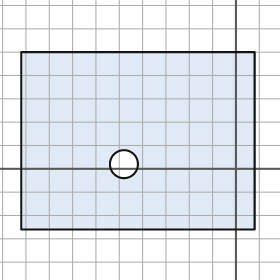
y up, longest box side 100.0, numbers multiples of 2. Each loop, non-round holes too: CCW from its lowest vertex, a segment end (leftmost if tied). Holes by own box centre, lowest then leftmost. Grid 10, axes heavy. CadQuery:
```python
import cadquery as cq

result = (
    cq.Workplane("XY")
    .moveTo(-92.0, -26.0)
    .lineTo(8.0, -26.0)
    .lineTo(8.0, 50.0)
    .lineTo(-92.0, 50.0)
    .close()
    .moveTo(-48.0, 2.0)
    .circle(6.0)
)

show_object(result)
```